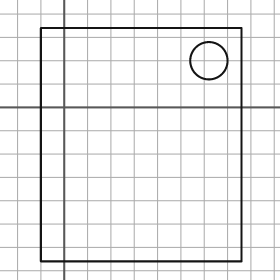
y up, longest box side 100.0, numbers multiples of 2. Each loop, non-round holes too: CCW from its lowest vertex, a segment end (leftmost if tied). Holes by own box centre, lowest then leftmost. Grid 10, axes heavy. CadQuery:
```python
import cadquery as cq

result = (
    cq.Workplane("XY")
    .moveTo(-10.0, -66.0)
    .lineTo(76.0, -66.0)
    .lineTo(76.0, 34.0)
    .lineTo(-10.0, 34.0)
    .close()
    .moveTo(62.0, 20.0)
    .circle(8.0)
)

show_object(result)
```